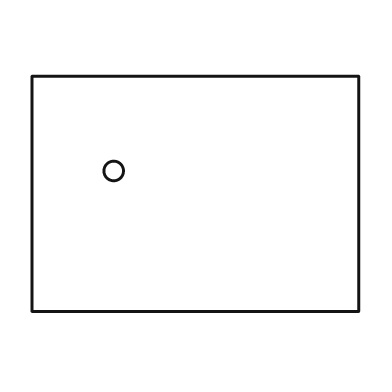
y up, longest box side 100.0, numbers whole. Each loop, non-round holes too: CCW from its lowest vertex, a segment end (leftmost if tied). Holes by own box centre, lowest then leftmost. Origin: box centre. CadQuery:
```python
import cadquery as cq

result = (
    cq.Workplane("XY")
    .moveTo(-50.0, -36.0)
    .lineTo(50.0, -36.0)
    .lineTo(50.0, 36.0)
    .lineTo(-50.0, 36.0)
    .close()
    .moveTo(-25.0, 7.0)
    .circle(3.0)
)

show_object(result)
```